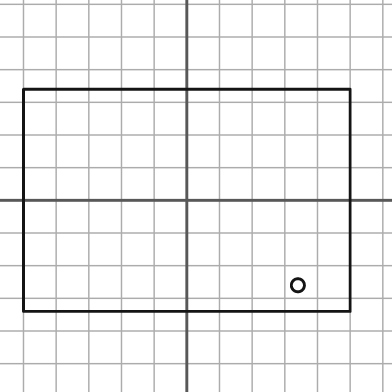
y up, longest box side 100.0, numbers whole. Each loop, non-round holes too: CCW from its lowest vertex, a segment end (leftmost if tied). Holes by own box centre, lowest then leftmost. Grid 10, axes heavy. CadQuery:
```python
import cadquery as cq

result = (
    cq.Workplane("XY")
    .moveTo(-50.0, -34.0)
    .lineTo(50.0, -34.0)
    .lineTo(50.0, 34.0)
    .lineTo(-50.0, 34.0)
    .close()
    .moveTo(34.0, -26.0)
    .circle(2.0)
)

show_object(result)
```